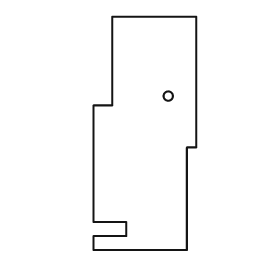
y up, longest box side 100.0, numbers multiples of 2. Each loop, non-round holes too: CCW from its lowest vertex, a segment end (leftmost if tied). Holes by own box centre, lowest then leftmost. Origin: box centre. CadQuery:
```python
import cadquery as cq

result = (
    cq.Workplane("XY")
    .moveTo(-22.0, -50.0)
    .lineTo(18.0, -50.0)
    .lineTo(18.0, -6.0)
    .lineTo(22.0, -6.0)
    .lineTo(22.0, 50.0)
    .lineTo(-14.0, 50.0)
    .lineTo(-14.0, 12.0)
    .lineTo(-22.0, 12.0)
    .lineTo(-22.0, -38.0)
    .lineTo(-8.0, -38.0)
    .lineTo(-8.0, -44.0)
    .lineTo(-22.0, -44.0)
    .close()
    .moveTo(10.0, 16.0)
    .circle(2.0)
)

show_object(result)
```